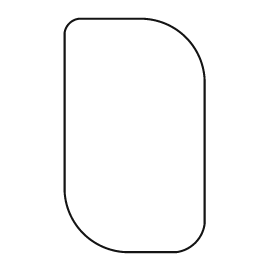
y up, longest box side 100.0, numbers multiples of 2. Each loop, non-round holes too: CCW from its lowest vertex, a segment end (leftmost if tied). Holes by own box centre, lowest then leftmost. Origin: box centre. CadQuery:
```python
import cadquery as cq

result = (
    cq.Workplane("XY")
    .moveTo(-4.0, -50.0)
    .lineTo(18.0, -50.0)
    .threePointArc((26.0, -46.0), (30.0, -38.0))
    .lineTo(30.0, 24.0)
    .threePointArc((22.0, 42.0), (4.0, 50.0))
    .lineTo(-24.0, 50.0)
    .threePointArc((-28.0, 48.0), (-30.0, 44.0))
    .lineTo(-30.0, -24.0)
    .threePointArc((-22.0, -42.0), (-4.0, -50.0))
    .close()
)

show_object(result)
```